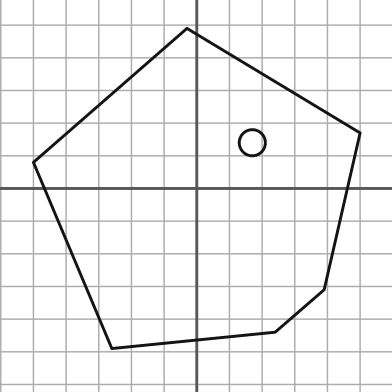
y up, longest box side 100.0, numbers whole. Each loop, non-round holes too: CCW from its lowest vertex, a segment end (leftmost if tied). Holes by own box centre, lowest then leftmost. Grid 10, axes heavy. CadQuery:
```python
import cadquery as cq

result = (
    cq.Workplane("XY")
    .moveTo(-26.0, -49.0)
    .lineTo(24.0, -44.0)
    .lineTo(39.0, -31.0)
    .lineTo(50.0, 17.0)
    .lineTo(-3.0, 49.0)
    .lineTo(-50.0, 8.0)
    .close()
    .moveTo(17.0, 14.0)
    .circle(4.0)
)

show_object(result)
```